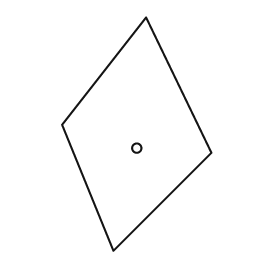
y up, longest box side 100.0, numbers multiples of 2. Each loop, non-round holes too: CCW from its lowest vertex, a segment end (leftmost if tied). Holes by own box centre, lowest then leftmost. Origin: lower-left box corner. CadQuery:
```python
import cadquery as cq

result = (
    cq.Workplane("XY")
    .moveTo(22.0, 0.0)
    .lineTo(64.0, 42.0)
    .lineTo(36.0, 100.0)
    .lineTo(0.0, 54.0)
    .close()
    .moveTo(32.0, 44.0)
    .circle(2.0)
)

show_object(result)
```